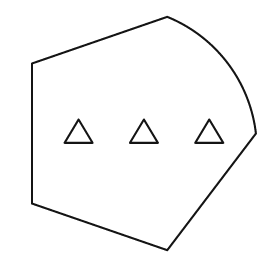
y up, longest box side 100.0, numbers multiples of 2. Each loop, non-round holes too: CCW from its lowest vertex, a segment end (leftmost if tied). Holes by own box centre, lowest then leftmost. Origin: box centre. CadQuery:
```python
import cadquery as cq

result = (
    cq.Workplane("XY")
    .moveTo(10.0, -50.0)
    .lineTo(48.0, 0.0)
    .threePointArc((36.0, 30.0), (10.0, 50.0))
    .lineTo(-48.0, 30.0)
    .lineTo(-48.0, -30.0)
    .close()
    .moveTo(-34.0, -4.0)
    .lineTo(-22.0, -4.0)
    .lineTo(-28.0, 6.0)
    .close()
    .moveTo(-6.0, -4.0)
    .lineTo(6.0, -4.0)
    .lineTo(0.0, 6.0)
    .close()
    .moveTo(22.0, -4.0)
    .lineTo(34.0, -4.0)
    .lineTo(28.0, 6.0)
    .close()
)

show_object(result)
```